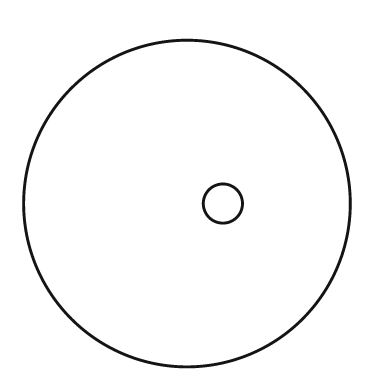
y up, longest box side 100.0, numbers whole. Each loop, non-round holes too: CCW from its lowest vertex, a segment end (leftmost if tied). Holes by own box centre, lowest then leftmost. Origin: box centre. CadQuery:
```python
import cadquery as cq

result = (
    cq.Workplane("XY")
    .moveTo(0.0, 0.0)
    .circle(50.0)
    .moveTo(11.0, 0.0)
    .circle(6.0)
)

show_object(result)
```